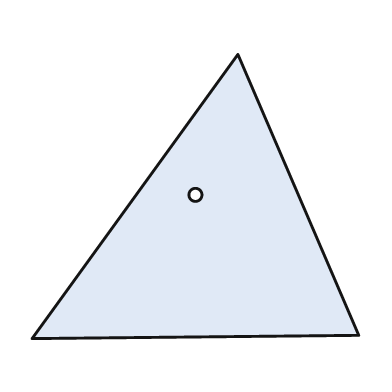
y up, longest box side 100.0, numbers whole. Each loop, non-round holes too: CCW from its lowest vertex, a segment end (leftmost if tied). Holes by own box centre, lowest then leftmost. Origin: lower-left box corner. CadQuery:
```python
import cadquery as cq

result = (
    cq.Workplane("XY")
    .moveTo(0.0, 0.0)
    .lineTo(100.0, 1.0)
    .lineTo(63.0, 87.0)
    .close()
    .moveTo(50.0, 44.0)
    .circle(2.0)
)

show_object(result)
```